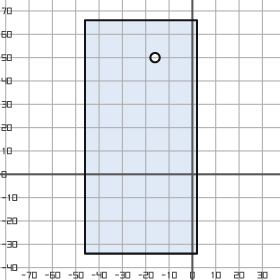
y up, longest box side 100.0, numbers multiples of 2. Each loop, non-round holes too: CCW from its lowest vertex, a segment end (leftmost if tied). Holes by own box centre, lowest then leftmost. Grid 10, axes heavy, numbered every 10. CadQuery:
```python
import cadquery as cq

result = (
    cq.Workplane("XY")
    .moveTo(-46.0, -34.0)
    .lineTo(2.0, -34.0)
    .lineTo(2.0, 66.0)
    .lineTo(-46.0, 66.0)
    .close()
    .moveTo(-16.0, 50.0)
    .circle(2.0)
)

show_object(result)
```